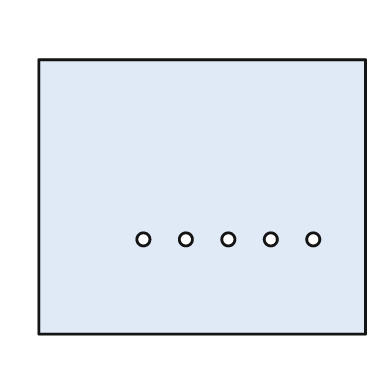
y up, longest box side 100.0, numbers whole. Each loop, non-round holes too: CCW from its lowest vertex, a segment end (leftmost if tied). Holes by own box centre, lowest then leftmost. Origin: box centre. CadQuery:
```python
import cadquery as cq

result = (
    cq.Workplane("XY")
    .moveTo(-50.0, -42.0)
    .lineTo(50.0, -42.0)
    .lineTo(50.0, 42.0)
    .lineTo(-50.0, 42.0)
    .close()
    .moveTo(-18.0, -13.0)
    .circle(2.0)
    .moveTo(-5.0, -13.0)
    .circle(2.0)
    .moveTo(8.0, -13.0)
    .circle(2.0)
    .moveTo(21.0, -13.0)
    .circle(2.0)
    .moveTo(34.0, -13.0)
    .circle(2.0)
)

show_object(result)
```